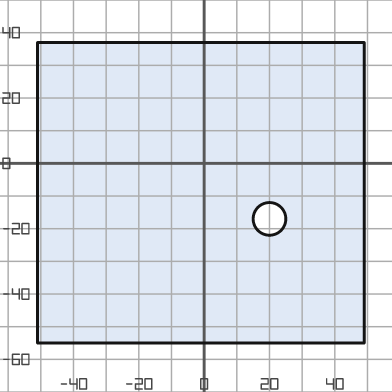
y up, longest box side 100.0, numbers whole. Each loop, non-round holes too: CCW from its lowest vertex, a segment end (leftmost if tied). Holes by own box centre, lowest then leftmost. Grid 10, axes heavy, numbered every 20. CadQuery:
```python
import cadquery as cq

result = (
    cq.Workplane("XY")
    .moveTo(-51.0, -55.0)
    .lineTo(49.0, -55.0)
    .lineTo(49.0, 37.0)
    .lineTo(-51.0, 37.0)
    .close()
    .moveTo(20.0, -17.0)
    .circle(5.0)
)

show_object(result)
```